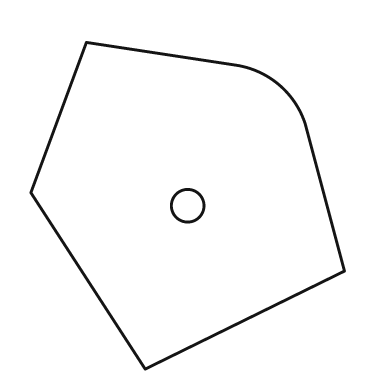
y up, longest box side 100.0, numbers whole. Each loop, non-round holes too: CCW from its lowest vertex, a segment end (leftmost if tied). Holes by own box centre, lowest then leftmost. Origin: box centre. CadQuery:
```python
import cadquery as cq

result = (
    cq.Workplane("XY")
    .moveTo(-13.0, -50.0)
    .lineTo(48.0, -20.0)
    .lineTo(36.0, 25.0)
    .threePointArc((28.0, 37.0), (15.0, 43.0))
    .lineTo(-31.0, 50.0)
    .lineTo(-48.0, 4.0)
    .close()
    .moveTo(0.0, 0.0)
    .circle(5.0)
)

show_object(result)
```